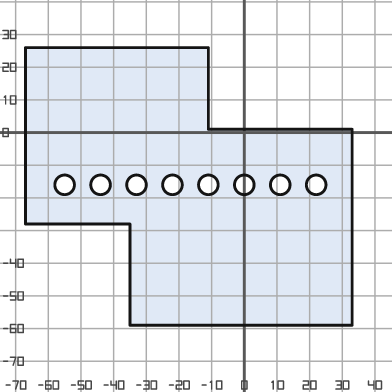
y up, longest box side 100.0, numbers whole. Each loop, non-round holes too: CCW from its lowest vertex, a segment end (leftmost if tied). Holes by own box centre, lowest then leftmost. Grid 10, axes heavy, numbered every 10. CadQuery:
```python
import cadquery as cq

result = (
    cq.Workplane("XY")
    .moveTo(-35.0, -59.0)
    .lineTo(33.0, -59.0)
    .lineTo(33.0, 1.0)
    .lineTo(-11.0, 1.0)
    .lineTo(-11.0, 26.0)
    .lineTo(-67.0, 26.0)
    .lineTo(-67.0, -28.0)
    .lineTo(-35.0, -28.0)
    .close()
    .moveTo(-55.0, -16.0)
    .circle(3.0)
    .moveTo(-44.0, -16.0)
    .circle(3.0)
    .moveTo(-33.0, -16.0)
    .circle(3.0)
    .moveTo(-22.0, -16.0)
    .circle(3.0)
    .moveTo(-11.0, -16.0)
    .circle(3.0)
    .moveTo(0.0, -16.0)
    .circle(3.0)
    .moveTo(11.0, -16.0)
    .circle(3.0)
    .moveTo(22.0, -16.0)
    .circle(3.0)
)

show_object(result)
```